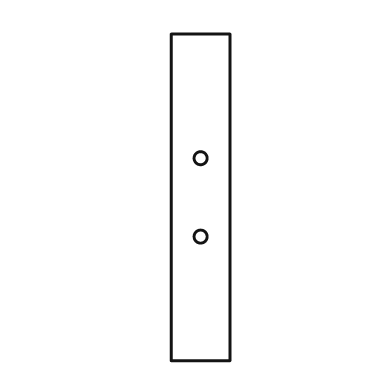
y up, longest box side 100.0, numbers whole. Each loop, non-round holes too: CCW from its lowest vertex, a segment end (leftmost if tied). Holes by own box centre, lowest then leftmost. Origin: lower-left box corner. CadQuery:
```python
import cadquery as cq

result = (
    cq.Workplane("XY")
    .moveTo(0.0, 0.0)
    .lineTo(18.0, 0.0)
    .lineTo(18.0, 100.0)
    .lineTo(0.0, 100.0)
    .close()
    .moveTo(9.0, 38.0)
    .circle(2.0)
    .moveTo(9.0, 62.0)
    .circle(2.0)
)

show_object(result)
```